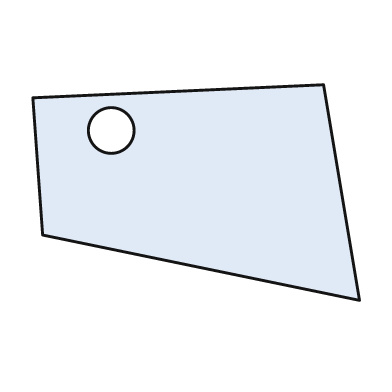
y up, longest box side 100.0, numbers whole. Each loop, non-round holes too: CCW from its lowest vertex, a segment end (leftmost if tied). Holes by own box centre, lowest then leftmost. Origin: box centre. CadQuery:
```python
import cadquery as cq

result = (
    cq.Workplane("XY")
    .moveTo(50.0, -33.0)
    .lineTo(39.0, 33.0)
    .lineTo(-50.0, 29.0)
    .lineTo(-47.0, -13.0)
    .close()
    .moveTo(-26.0, 19.0)
    .circle(7.0)
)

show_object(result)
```